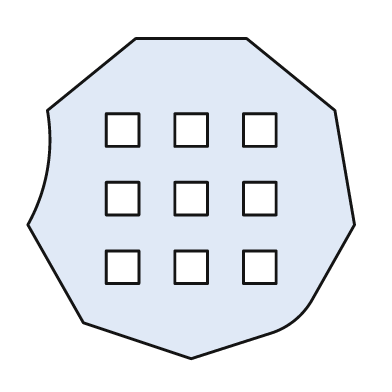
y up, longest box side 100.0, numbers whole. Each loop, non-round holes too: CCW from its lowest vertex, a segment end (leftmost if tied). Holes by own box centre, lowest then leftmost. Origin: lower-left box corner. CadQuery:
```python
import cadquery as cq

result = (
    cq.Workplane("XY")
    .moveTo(50.0, 0.0)
    .lineTo(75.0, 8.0)
    .threePointArc((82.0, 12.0), (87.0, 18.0))
    .lineTo(100.0, 41.0)
    .lineTo(94.0, 76.0)
    .lineTo(67.0, 98.0)
    .lineTo(33.0, 98.0)
    .lineTo(6.0, 76.0)
    .threePointArc((6.0, 58.0), (0.0, 41.0))
    .lineTo(17.0, 11.0)
    .close()
    .moveTo(24.0, 23.0)
    .lineTo(34.0, 23.0)
    .lineTo(34.0, 33.0)
    .lineTo(24.0, 33.0)
    .close()
    .moveTo(45.0, 23.0)
    .lineTo(55.0, 23.0)
    .lineTo(55.0, 33.0)
    .lineTo(45.0, 33.0)
    .close()
    .moveTo(66.0, 23.0)
    .lineTo(76.0, 23.0)
    .lineTo(76.0, 33.0)
    .lineTo(66.0, 33.0)
    .close()
    .moveTo(24.0, 44.0)
    .lineTo(34.0, 44.0)
    .lineTo(34.0, 54.0)
    .lineTo(24.0, 54.0)
    .close()
    .moveTo(45.0, 44.0)
    .lineTo(55.0, 44.0)
    .lineTo(55.0, 54.0)
    .lineTo(45.0, 54.0)
    .close()
    .moveTo(66.0, 44.0)
    .lineTo(76.0, 44.0)
    .lineTo(76.0, 54.0)
    .lineTo(66.0, 54.0)
    .close()
    .moveTo(24.0, 65.0)
    .lineTo(34.0, 65.0)
    .lineTo(34.0, 75.0)
    .lineTo(24.0, 75.0)
    .close()
    .moveTo(45.0, 65.0)
    .lineTo(55.0, 65.0)
    .lineTo(55.0, 75.0)
    .lineTo(45.0, 75.0)
    .close()
    .moveTo(66.0, 65.0)
    .lineTo(76.0, 65.0)
    .lineTo(76.0, 75.0)
    .lineTo(66.0, 75.0)
    .close()
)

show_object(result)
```